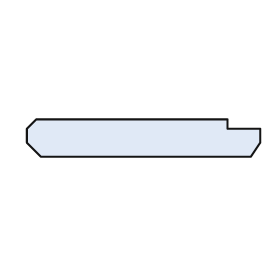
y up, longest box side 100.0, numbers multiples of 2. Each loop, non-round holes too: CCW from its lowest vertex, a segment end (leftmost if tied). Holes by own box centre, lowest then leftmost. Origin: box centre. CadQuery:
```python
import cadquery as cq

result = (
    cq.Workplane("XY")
    .moveTo(-44.0, -8.0)
    .lineTo(46.0, -8.0)
    .lineTo(50.0, -2.0)
    .lineTo(50.0, 4.0)
    .lineTo(36.0, 4.0)
    .lineTo(36.0, 8.0)
    .lineTo(-46.0, 8.0)
    .lineTo(-50.0, 4.0)
    .lineTo(-50.0, -2.0)
    .close()
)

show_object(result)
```